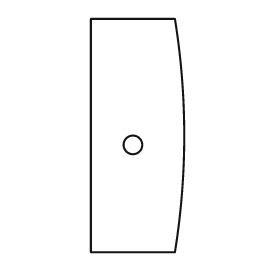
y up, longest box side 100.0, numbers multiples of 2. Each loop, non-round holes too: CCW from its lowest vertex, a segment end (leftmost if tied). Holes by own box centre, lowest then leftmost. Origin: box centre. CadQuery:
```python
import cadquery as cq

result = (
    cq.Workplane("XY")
    .moveTo(-20.0, -50.0)
    .lineTo(16.0, -50.0)
    .threePointArc((20.0, 0.0), (16.0, 50.0))
    .lineTo(-20.0, 50.0)
    .close()
    .moveTo(-2.0, -4.0)
    .circle(4.0)
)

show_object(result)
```